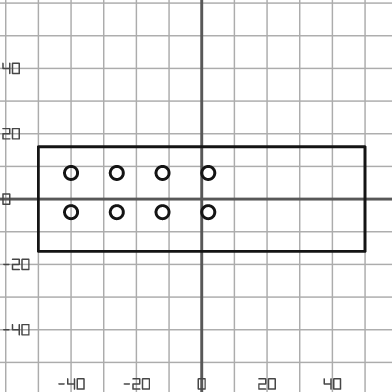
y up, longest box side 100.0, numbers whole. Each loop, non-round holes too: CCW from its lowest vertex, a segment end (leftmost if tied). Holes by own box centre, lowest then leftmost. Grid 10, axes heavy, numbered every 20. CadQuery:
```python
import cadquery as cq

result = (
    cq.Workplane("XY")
    .moveTo(-50.0, -16.0)
    .lineTo(50.0, -16.0)
    .lineTo(50.0, 16.0)
    .lineTo(-50.0, 16.0)
    .close()
    .moveTo(-40.0, -4.0)
    .circle(2.0)
    .moveTo(-26.0, -4.0)
    .circle(2.0)
    .moveTo(-12.0, -4.0)
    .circle(2.0)
    .moveTo(2.0, -4.0)
    .circle(2.0)
    .moveTo(-40.0, 8.0)
    .circle(2.0)
    .moveTo(-26.0, 8.0)
    .circle(2.0)
    .moveTo(-12.0, 8.0)
    .circle(2.0)
    .moveTo(2.0, 8.0)
    .circle(2.0)
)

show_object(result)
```